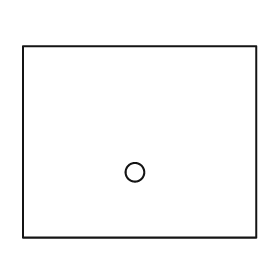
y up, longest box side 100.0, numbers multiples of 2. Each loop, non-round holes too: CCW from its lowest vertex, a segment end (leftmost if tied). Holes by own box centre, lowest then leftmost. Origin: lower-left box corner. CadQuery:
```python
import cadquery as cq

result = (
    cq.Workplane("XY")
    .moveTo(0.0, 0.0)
    .lineTo(100.0, 0.0)
    .lineTo(100.0, 82.0)
    .lineTo(0.0, 82.0)
    .close()
    .moveTo(48.0, 28.0)
    .circle(4.0)
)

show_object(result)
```